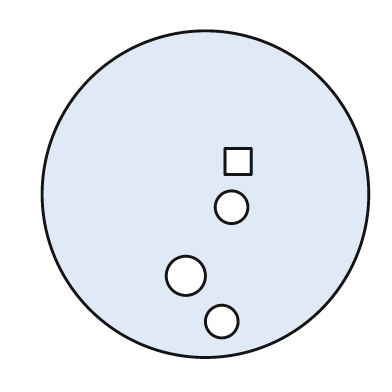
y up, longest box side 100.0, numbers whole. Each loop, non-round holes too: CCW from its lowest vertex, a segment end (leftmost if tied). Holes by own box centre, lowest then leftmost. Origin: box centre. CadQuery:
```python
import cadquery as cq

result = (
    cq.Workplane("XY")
    .moveTo(0.0, 0.0)
    .circle(50.0)
    .moveTo(5.0, -39.0)
    .circle(5.0)
    .moveTo(-6.0, -25.0)
    .circle(6.0)
    .moveTo(8.0, -4.0)
    .circle(5.0)
    .moveTo(6.0, 6.0)
    .lineTo(14.0, 6.0)
    .lineTo(14.0, 14.0)
    .lineTo(6.0, 14.0)
    .close()
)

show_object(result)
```